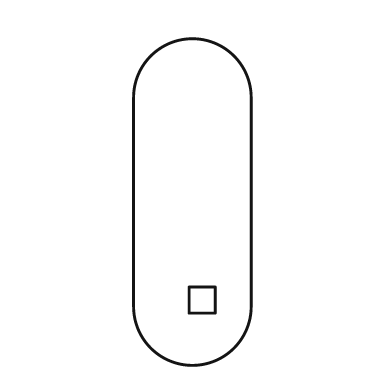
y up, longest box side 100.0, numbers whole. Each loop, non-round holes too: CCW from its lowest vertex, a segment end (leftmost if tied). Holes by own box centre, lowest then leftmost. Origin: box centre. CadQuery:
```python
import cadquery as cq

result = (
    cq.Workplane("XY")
    .moveTo(-18.0, -32.0)
    .threePointArc((0.0, -50.0), (18.0, -32.0))
    .lineTo(18.0, 32.0)
    .threePointArc((0.0, 50.0), (-18.0, 32.0))
    .close()
    .moveTo(-1.0, -34.0)
    .lineTo(7.0, -34.0)
    .lineTo(7.0, -26.0)
    .lineTo(-1.0, -26.0)
    .close()
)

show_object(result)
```